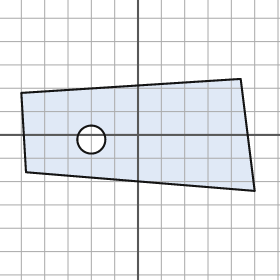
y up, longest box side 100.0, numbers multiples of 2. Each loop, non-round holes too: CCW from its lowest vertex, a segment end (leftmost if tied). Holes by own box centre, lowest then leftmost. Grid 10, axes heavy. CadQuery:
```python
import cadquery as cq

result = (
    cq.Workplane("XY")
    .moveTo(50.0, -24.0)
    .lineTo(44.0, 24.0)
    .lineTo(-50.0, 18.0)
    .lineTo(-48.0, -16.0)
    .close()
    .moveTo(-20.0, -2.0)
    .circle(6.0)
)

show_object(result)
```